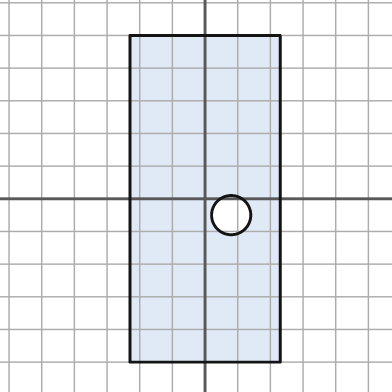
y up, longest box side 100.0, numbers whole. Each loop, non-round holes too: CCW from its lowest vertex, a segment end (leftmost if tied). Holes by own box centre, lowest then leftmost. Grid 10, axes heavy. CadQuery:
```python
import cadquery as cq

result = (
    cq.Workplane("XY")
    .moveTo(-23.0, -50.0)
    .lineTo(23.0, -50.0)
    .lineTo(23.0, 50.0)
    .lineTo(-23.0, 50.0)
    .close()
    .moveTo(8.0, -5.0)
    .circle(6.0)
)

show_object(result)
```